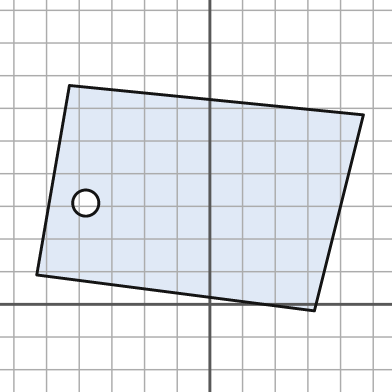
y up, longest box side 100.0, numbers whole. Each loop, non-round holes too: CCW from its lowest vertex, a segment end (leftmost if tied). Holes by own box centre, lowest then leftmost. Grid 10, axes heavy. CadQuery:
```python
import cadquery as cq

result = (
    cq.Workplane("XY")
    .moveTo(32.0, -2.0)
    .lineTo(47.0, 58.0)
    .lineTo(-43.0, 67.0)
    .lineTo(-53.0, 9.0)
    .close()
    .moveTo(-38.0, 31.0)
    .circle(4.0)
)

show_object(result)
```